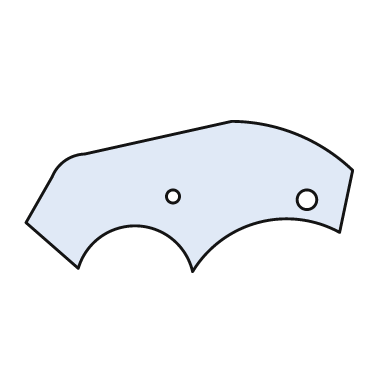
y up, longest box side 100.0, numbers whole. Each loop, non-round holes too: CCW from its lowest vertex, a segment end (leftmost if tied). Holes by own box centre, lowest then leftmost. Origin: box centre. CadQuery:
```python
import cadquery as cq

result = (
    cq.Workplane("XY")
    .moveTo(1.0, -23.0)
    .threePointArc((21.0, -8.0), (46.0, -11.0))
    .lineTo(50.0, 8.0)
    .threePointArc((33.0, 19.0), (13.0, 23.0))
    .lineTo(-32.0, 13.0)
    .threePointArc((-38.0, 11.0), (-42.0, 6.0))
    .lineTo(-50.0, -8.0)
    .lineTo(-34.0, -22.0)
    .threePointArc((-16.0, -9.0), (1.0, -23.0))
    .close()
    .moveTo(36.0, -1.0)
    .circle(3.0)
    .moveTo(-5.0, 0.0)
    .circle(2.0)
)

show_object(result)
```